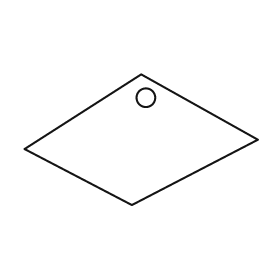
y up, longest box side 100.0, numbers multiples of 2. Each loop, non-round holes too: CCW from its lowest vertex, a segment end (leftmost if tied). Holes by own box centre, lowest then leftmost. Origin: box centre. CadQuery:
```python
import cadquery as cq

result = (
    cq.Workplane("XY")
    .moveTo(-4.0, -28.0)
    .lineTo(50.0, 0.0)
    .lineTo(0.0, 28.0)
    .lineTo(-50.0, -4.0)
    .close()
    .moveTo(2.0, 18.0)
    .circle(4.0)
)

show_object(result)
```